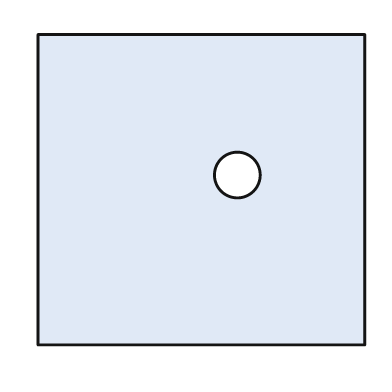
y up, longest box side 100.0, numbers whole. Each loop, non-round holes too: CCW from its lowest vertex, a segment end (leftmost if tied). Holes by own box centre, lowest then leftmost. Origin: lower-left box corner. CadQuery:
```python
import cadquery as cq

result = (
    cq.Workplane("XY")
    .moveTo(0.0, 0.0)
    .lineTo(100.0, 0.0)
    .lineTo(100.0, 95.0)
    .lineTo(0.0, 95.0)
    .close()
    .moveTo(61.0, 52.0)
    .circle(7.0)
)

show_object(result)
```